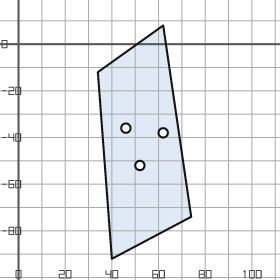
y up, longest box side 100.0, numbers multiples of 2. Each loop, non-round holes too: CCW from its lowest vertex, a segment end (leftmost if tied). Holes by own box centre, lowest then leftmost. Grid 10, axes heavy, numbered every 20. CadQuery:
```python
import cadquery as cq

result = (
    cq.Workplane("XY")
    .moveTo(40.0, -92.0)
    .lineTo(74.0, -74.0)
    .lineTo(62.0, 8.0)
    .lineTo(34.0, -12.0)
    .close()
    .moveTo(52.0, -52.0)
    .circle(2.0)
    .moveTo(62.0, -38.0)
    .circle(2.0)
    .moveTo(46.0, -36.0)
    .circle(2.0)
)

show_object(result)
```